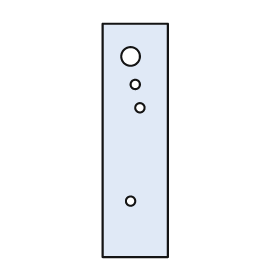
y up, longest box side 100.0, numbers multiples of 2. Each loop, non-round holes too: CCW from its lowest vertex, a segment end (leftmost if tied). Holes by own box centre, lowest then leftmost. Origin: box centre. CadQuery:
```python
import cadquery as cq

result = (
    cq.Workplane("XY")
    .moveTo(-14.0, -50.0)
    .lineTo(14.0, -50.0)
    .lineTo(14.0, 50.0)
    .lineTo(-14.0, 50.0)
    .close()
    .moveTo(-2.0, -26.0)
    .circle(2.0)
    .moveTo(2.0, 14.0)
    .circle(2.0)
    .moveTo(0.0, 24.0)
    .circle(2.0)
    .moveTo(-2.0, 36.0)
    .circle(4.0)
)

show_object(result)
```